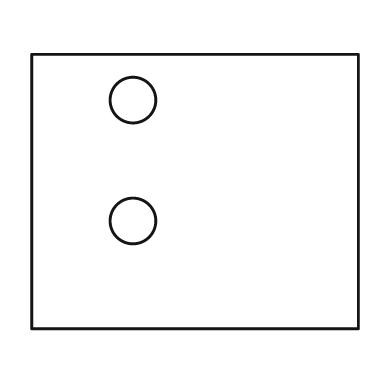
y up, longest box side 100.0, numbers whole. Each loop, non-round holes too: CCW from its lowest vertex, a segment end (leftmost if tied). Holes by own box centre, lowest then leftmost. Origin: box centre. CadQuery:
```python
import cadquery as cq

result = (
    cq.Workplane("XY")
    .moveTo(-50.0, -42.0)
    .lineTo(50.0, -42.0)
    .lineTo(50.0, 42.0)
    .lineTo(-50.0, 42.0)
    .close()
    .moveTo(-19.0, -9.0)
    .circle(7.0)
    .moveTo(-19.0, 28.0)
    .circle(7.0)
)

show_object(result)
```